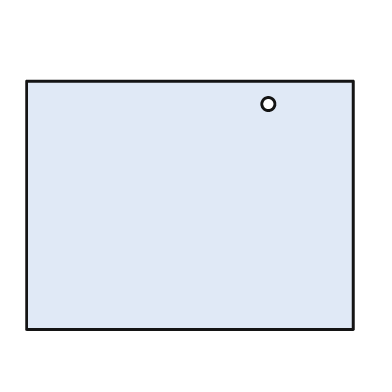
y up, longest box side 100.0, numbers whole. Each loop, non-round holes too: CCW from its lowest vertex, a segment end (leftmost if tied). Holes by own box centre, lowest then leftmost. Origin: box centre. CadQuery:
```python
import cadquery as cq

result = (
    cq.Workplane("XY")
    .moveTo(-50.0, -38.0)
    .lineTo(50.0, -38.0)
    .lineTo(50.0, 38.0)
    .lineTo(-50.0, 38.0)
    .close()
    .moveTo(24.0, 31.0)
    .circle(2.0)
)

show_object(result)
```